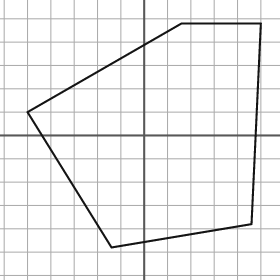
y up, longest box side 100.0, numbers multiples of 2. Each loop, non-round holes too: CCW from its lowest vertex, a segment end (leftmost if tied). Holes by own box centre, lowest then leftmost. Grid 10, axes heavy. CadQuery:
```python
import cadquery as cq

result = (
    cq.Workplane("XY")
    .moveTo(-14.0, -48.0)
    .lineTo(46.0, -38.0)
    .lineTo(50.0, 48.0)
    .lineTo(16.0, 48.0)
    .lineTo(-50.0, 10.0)
    .close()
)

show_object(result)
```